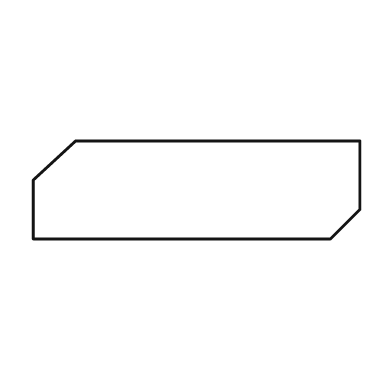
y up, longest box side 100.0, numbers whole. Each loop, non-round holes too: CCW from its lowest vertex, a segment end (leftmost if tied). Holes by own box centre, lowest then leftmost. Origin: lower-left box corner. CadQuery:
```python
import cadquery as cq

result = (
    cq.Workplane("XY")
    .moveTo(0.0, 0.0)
    .lineTo(91.0, 0.0)
    .lineTo(100.0, 9.0)
    .lineTo(100.0, 30.0)
    .lineTo(13.0, 30.0)
    .lineTo(0.0, 18.0)
    .close()
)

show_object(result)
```